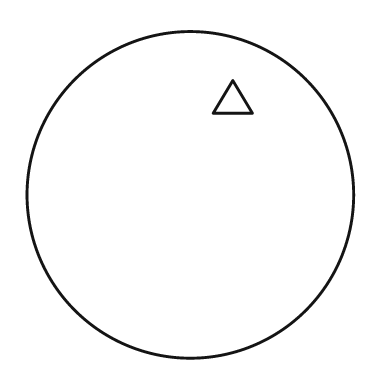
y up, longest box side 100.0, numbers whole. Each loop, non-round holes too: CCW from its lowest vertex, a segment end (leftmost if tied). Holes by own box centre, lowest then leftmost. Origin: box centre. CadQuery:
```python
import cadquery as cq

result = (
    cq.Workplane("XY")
    .moveTo(0.0, 0.0)
    .circle(50.0)
    .moveTo(7.0, 25.0)
    .lineTo(19.0, 25.0)
    .lineTo(13.0, 35.0)
    .close()
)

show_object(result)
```